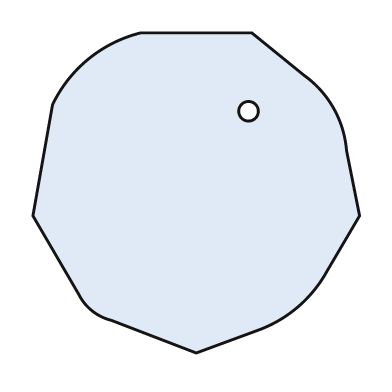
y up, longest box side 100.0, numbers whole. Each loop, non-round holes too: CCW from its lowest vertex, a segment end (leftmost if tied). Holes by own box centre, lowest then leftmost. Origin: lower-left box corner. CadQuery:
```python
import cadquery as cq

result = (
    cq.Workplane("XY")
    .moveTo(50.0, 0.0)
    .lineTo(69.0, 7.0)
    .threePointArc((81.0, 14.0), (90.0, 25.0))
    .lineTo(100.0, 42.0)
    .lineTo(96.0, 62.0)
    .threePointArc((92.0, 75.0), (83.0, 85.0))
    .lineTo(67.0, 98.0)
    .lineTo(33.0, 98.0)
    .threePointArc((17.0, 90.0), (6.0, 76.0))
    .lineTo(0.0, 42.0)
    .lineTo(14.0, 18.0)
    .threePointArc((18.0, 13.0), (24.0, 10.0))
    .close()
    .moveTo(66.0, 74.0)
    .circle(3.0)
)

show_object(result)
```